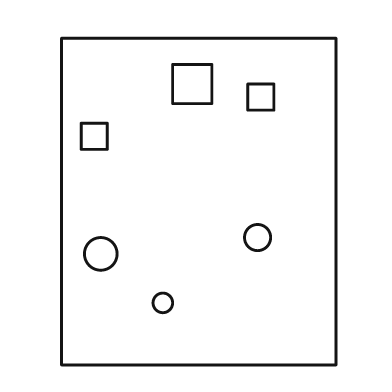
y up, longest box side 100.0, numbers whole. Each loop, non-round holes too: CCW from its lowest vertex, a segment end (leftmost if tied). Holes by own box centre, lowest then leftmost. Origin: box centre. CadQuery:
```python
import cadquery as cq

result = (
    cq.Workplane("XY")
    .moveTo(-42.0, -50.0)
    .lineTo(42.0, -50.0)
    .lineTo(42.0, 50.0)
    .lineTo(-42.0, 50.0)
    .close()
    .moveTo(-11.0, -31.0)
    .circle(3.0)
    .moveTo(-30.0, -16.0)
    .circle(5.0)
    .moveTo(18.0, -11.0)
    .circle(4.0)
    .moveTo(-36.0, 16.0)
    .lineTo(-28.0, 16.0)
    .lineTo(-28.0, 24.0)
    .lineTo(-36.0, 24.0)
    .close()
    .moveTo(15.0, 28.0)
    .lineTo(23.0, 28.0)
    .lineTo(23.0, 36.0)
    .lineTo(15.0, 36.0)
    .close()
    .moveTo(-8.0, 30.0)
    .lineTo(4.0, 30.0)
    .lineTo(4.0, 42.0)
    .lineTo(-8.0, 42.0)
    .close()
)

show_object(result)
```